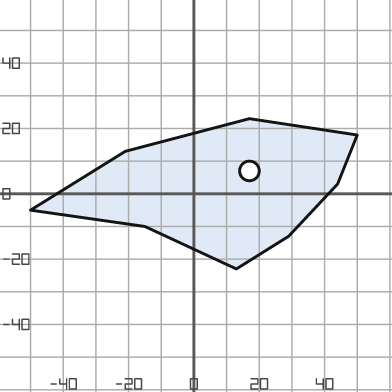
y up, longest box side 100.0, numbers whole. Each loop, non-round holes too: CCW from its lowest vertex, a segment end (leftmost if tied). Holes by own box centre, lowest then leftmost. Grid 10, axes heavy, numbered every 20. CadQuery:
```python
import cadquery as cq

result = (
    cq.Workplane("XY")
    .moveTo(13.0, -23.0)
    .lineTo(29.0, -13.0)
    .lineTo(44.0, 3.0)
    .lineTo(50.0, 18.0)
    .lineTo(17.0, 23.0)
    .lineTo(-21.0, 13.0)
    .lineTo(-50.0, -5.0)
    .lineTo(-15.0, -10.0)
    .close()
    .moveTo(17.0, 7.0)
    .circle(3.0)
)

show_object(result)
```